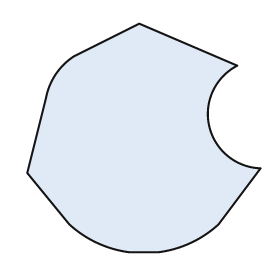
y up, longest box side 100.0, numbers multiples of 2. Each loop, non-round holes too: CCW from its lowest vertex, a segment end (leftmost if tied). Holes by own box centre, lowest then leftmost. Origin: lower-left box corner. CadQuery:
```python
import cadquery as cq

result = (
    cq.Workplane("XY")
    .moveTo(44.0, 0.0)
    .lineTo(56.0, 0.0)
    .threePointArc((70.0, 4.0), (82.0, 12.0))
    .lineTo(100.0, 36.0)
    .threePointArc((78.0, 54.0), (90.0, 80.0))
    .lineTo(48.0, 98.0)
    .lineTo(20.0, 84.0)
    .threePointArc((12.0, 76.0), (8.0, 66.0))
    .lineTo(0.0, 34.0)
    .lineTo(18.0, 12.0)
    .threePointArc((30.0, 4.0), (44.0, 0.0))
    .close()
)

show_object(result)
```